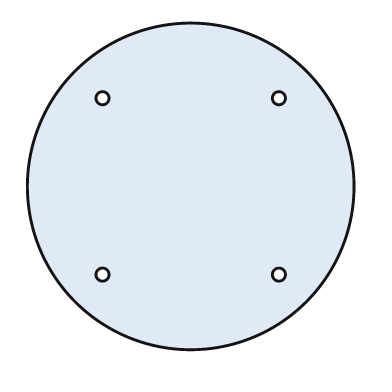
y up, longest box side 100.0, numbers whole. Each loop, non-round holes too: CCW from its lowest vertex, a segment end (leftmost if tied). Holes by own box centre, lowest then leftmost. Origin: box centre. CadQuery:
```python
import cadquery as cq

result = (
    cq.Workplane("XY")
    .moveTo(0.0, 0.0)
    .circle(50.0)
    .moveTo(-27.0, -27.0)
    .circle(2.0)
    .moveTo(27.0, -27.0)
    .circle(2.0)
    .moveTo(-27.0, 27.0)
    .circle(2.0)
    .moveTo(27.0, 27.0)
    .circle(2.0)
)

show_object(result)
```